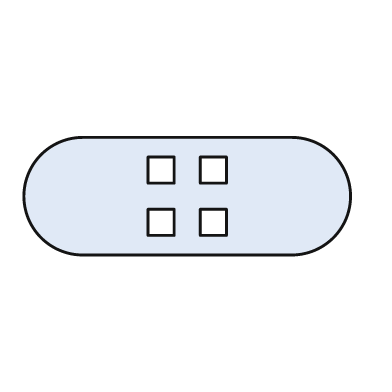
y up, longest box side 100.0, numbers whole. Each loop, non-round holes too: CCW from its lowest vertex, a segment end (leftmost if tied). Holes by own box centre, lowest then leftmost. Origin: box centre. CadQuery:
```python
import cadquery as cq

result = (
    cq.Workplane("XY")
    .moveTo(-32.0, -18.0)
    .lineTo(32.0, -18.0)
    .threePointArc((50.0, 0.0), (32.0, 18.0))
    .lineTo(-32.0, 18.0)
    .threePointArc((-50.0, 0.0), (-32.0, -18.0))
    .close()
    .moveTo(-12.0, -12.0)
    .lineTo(-4.0, -12.0)
    .lineTo(-4.0, -4.0)
    .lineTo(-12.0, -4.0)
    .close()
    .moveTo(4.0, -12.0)
    .lineTo(12.0, -12.0)
    .lineTo(12.0, -4.0)
    .lineTo(4.0, -4.0)
    .close()
    .moveTo(-12.0, 4.0)
    .lineTo(-4.0, 4.0)
    .lineTo(-4.0, 12.0)
    .lineTo(-12.0, 12.0)
    .close()
    .moveTo(4.0, 4.0)
    .lineTo(12.0, 4.0)
    .lineTo(12.0, 12.0)
    .lineTo(4.0, 12.0)
    .close()
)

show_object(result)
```